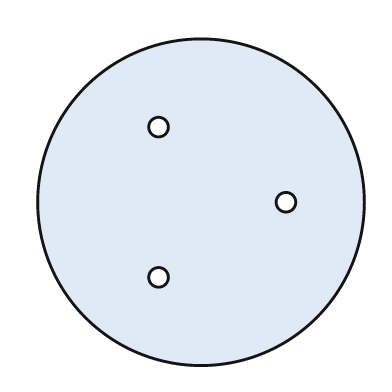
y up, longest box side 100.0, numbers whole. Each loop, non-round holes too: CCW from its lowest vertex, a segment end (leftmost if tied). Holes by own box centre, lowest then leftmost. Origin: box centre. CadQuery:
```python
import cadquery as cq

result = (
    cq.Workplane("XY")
    .moveTo(0.0, 0.0)
    .circle(50.0)
    .moveTo(-13.0, -23.0)
    .circle(3.0)
    .moveTo(26.0, 0.0)
    .circle(3.0)
    .moveTo(-13.0, 23.0)
    .circle(3.0)
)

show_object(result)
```